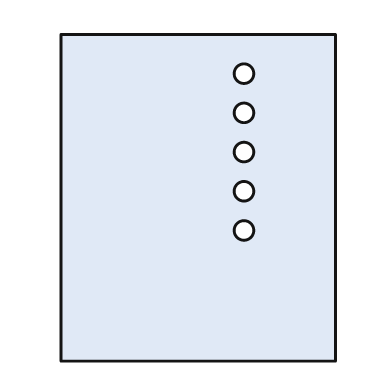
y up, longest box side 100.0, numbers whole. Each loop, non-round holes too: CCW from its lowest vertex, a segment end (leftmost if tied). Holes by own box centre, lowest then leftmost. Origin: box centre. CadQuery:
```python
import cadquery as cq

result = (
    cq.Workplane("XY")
    .moveTo(-42.0, -50.0)
    .lineTo(42.0, -50.0)
    .lineTo(42.0, 50.0)
    .lineTo(-42.0, 50.0)
    .close()
    .moveTo(14.0, -10.0)
    .circle(3.0)
    .moveTo(14.0, 2.0)
    .circle(3.0)
    .moveTo(14.0, 14.0)
    .circle(3.0)
    .moveTo(14.0, 26.0)
    .circle(3.0)
    .moveTo(14.0, 38.0)
    .circle(3.0)
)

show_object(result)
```